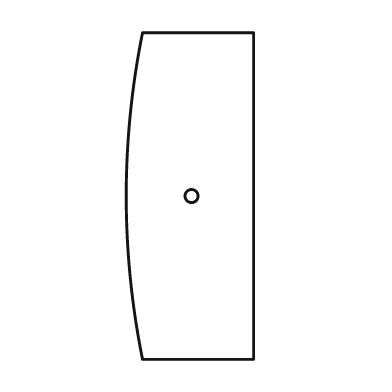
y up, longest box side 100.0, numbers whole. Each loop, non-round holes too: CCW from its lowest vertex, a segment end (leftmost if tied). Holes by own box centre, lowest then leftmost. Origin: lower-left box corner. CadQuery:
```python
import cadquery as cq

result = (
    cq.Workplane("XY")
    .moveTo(5.0, 0.0)
    .lineTo(39.0, 0.0)
    .lineTo(39.0, 100.0)
    .lineTo(5.0, 100.0)
    .threePointArc((0.0, 50.0), (5.0, 0.0))
    .close()
    .moveTo(20.0, 50.0)
    .circle(2.0)
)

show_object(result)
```